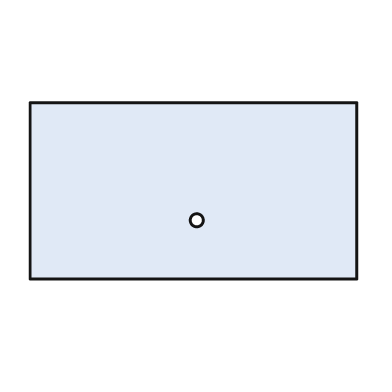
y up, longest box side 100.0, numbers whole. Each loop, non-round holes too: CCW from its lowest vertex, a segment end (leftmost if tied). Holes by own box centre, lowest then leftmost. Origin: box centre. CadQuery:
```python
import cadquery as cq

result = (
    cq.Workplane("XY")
    .moveTo(-50.0, -27.0)
    .lineTo(50.0, -27.0)
    .lineTo(50.0, 27.0)
    .lineTo(-50.0, 27.0)
    .close()
    .moveTo(1.0, -9.0)
    .circle(2.0)
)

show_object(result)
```